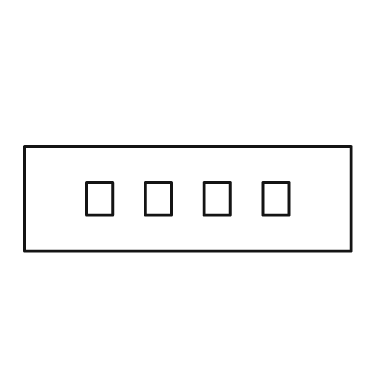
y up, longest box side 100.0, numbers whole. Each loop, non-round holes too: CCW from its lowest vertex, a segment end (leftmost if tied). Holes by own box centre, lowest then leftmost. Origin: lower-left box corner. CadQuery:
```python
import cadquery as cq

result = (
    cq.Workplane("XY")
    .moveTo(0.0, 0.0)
    .lineTo(100.0, 0.0)
    .lineTo(100.0, 32.0)
    .lineTo(0.0, 32.0)
    .close()
    .moveTo(19.0, 11.0)
    .lineTo(27.0, 11.0)
    .lineTo(27.0, 21.0)
    .lineTo(19.0, 21.0)
    .close()
    .moveTo(37.0, 11.0)
    .lineTo(45.0, 11.0)
    .lineTo(45.0, 21.0)
    .lineTo(37.0, 21.0)
    .close()
    .moveTo(55.0, 11.0)
    .lineTo(63.0, 11.0)
    .lineTo(63.0, 21.0)
    .lineTo(55.0, 21.0)
    .close()
    .moveTo(73.0, 11.0)
    .lineTo(81.0, 11.0)
    .lineTo(81.0, 21.0)
    .lineTo(73.0, 21.0)
    .close()
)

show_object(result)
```